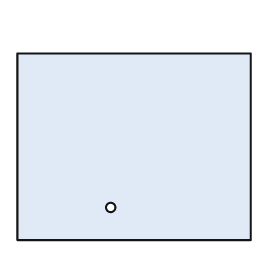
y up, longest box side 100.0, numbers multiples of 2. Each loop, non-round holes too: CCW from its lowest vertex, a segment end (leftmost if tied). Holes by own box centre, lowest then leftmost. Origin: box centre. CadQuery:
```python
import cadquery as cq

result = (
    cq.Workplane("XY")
    .moveTo(-50.0, -40.0)
    .lineTo(50.0, -40.0)
    .lineTo(50.0, 40.0)
    .lineTo(-50.0, 40.0)
    .close()
    .moveTo(-10.0, -26.0)
    .circle(2.0)
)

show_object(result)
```